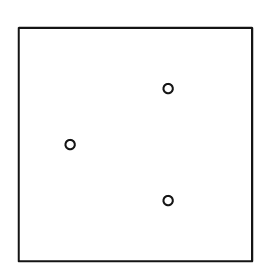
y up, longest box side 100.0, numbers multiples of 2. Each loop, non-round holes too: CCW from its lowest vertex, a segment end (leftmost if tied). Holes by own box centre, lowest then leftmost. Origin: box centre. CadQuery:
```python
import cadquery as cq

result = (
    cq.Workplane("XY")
    .moveTo(-50.0, -50.0)
    .lineTo(50.0, -50.0)
    .lineTo(50.0, 50.0)
    .lineTo(-50.0, 50.0)
    .close()
    .moveTo(14.0, -24.0)
    .circle(2.0)
    .moveTo(-28.0, 0.0)
    .circle(2.0)
    .moveTo(14.0, 24.0)
    .circle(2.0)
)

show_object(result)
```